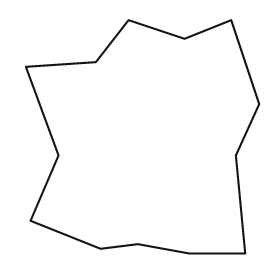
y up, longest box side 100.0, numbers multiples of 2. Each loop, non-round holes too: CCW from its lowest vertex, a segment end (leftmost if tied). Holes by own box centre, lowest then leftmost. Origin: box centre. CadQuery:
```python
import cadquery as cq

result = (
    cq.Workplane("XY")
    .moveTo(20.0, -50.0)
    .lineTo(44.0, -50.0)
    .lineTo(40.0, -8.0)
    .lineTo(50.0, 14.0)
    .lineTo(38.0, 50.0)
    .lineTo(18.0, 42.0)
    .lineTo(-6.0, 50.0)
    .lineTo(-20.0, 32.0)
    .lineTo(-50.0, 30.0)
    .lineTo(-36.0, -8.0)
    .lineTo(-48.0, -36.0)
    .lineTo(-18.0, -48.0)
    .lineTo(-2.0, -46.0)
    .close()
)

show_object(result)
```